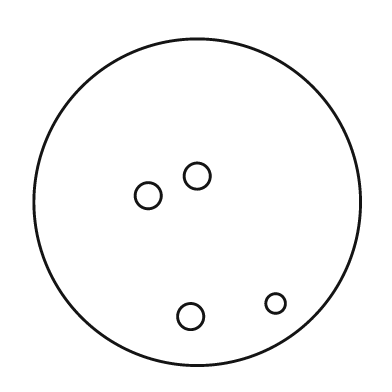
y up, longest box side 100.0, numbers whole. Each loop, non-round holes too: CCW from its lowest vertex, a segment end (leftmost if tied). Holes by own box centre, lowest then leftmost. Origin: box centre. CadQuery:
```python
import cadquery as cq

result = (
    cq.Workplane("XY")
    .moveTo(0.0, 0.0)
    .circle(50.0)
    .moveTo(-2.0, -35.0)
    .circle(4.0)
    .moveTo(24.0, -31.0)
    .circle(3.0)
    .moveTo(-15.0, 2.0)
    .circle(4.0)
    .moveTo(0.0, 8.0)
    .circle(4.0)
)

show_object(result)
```